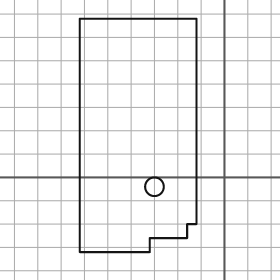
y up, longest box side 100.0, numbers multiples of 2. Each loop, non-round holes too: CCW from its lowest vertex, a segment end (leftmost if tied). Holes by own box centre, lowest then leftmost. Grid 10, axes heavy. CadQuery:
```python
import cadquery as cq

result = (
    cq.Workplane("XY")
    .moveTo(-62.0, -32.0)
    .lineTo(-32.0, -32.0)
    .lineTo(-32.0, -26.0)
    .lineTo(-16.0, -26.0)
    .lineTo(-16.0, -20.0)
    .lineTo(-12.0, -20.0)
    .lineTo(-12.0, 68.0)
    .lineTo(-62.0, 68.0)
    .close()
    .moveTo(-30.0, -4.0)
    .circle(4.0)
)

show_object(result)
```